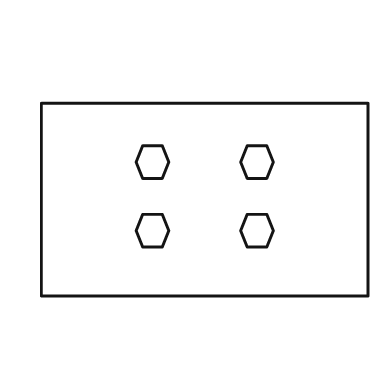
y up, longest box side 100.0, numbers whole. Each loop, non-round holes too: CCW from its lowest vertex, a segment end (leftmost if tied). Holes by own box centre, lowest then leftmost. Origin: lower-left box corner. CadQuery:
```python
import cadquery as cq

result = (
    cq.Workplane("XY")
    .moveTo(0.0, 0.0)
    .lineTo(100.0, 0.0)
    .lineTo(100.0, 59.0)
    .lineTo(0.0, 59.0)
    .close()
    .moveTo(31.0, 15.0)
    .lineTo(37.0, 15.0)
    .lineTo(39.0, 20.0)
    .lineTo(37.0, 25.0)
    .lineTo(31.0, 25.0)
    .lineTo(29.0, 20.0)
    .close()
    .moveTo(63.0, 15.0)
    .lineTo(69.0, 15.0)
    .lineTo(71.0, 20.0)
    .lineTo(69.0, 25.0)
    .lineTo(63.0, 25.0)
    .lineTo(61.0, 20.0)
    .close()
    .moveTo(31.0, 36.0)
    .lineTo(37.0, 36.0)
    .lineTo(39.0, 41.0)
    .lineTo(37.0, 46.0)
    .lineTo(31.0, 46.0)
    .lineTo(29.0, 41.0)
    .close()
    .moveTo(63.0, 36.0)
    .lineTo(69.0, 36.0)
    .lineTo(71.0, 41.0)
    .lineTo(69.0, 46.0)
    .lineTo(63.0, 46.0)
    .lineTo(61.0, 41.0)
    .close()
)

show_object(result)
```